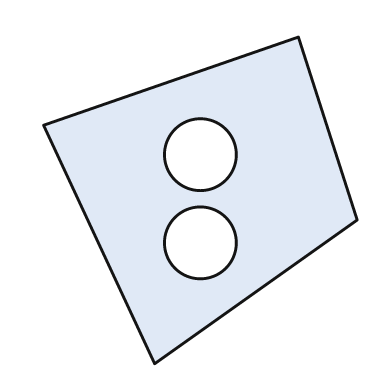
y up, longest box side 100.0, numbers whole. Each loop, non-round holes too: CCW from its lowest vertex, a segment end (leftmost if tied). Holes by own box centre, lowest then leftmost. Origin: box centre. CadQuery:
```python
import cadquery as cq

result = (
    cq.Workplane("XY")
    .moveTo(-14.0, -50.0)
    .lineTo(48.0, -6.0)
    .lineTo(30.0, 50.0)
    .lineTo(-48.0, 23.0)
    .close()
    .moveTo(0.0, -13.0)
    .circle(11.0)
    .moveTo(0.0, 14.0)
    .circle(11.0)
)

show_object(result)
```